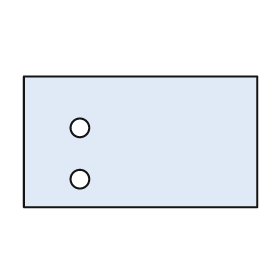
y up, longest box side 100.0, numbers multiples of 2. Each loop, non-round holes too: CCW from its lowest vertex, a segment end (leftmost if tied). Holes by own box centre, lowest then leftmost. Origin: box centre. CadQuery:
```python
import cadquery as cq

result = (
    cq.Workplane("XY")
    .moveTo(-50.0, -28.0)
    .lineTo(50.0, -28.0)
    .lineTo(50.0, 28.0)
    .lineTo(-50.0, 28.0)
    .close()
    .moveTo(-26.0, -16.0)
    .circle(4.0)
    .moveTo(-26.0, 6.0)
    .circle(4.0)
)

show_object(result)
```